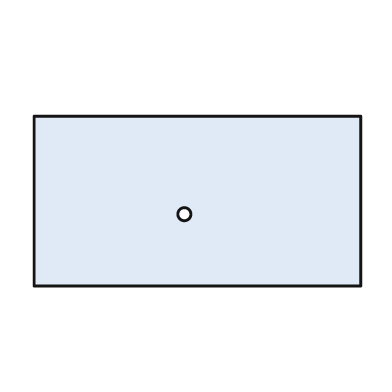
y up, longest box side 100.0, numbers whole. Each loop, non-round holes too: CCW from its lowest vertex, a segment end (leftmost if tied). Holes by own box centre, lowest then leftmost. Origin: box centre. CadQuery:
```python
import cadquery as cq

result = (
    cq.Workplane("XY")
    .moveTo(-50.0, -26.0)
    .lineTo(50.0, -26.0)
    .lineTo(50.0, 26.0)
    .lineTo(-50.0, 26.0)
    .close()
    .moveTo(-4.0, -4.0)
    .circle(2.0)
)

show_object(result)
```